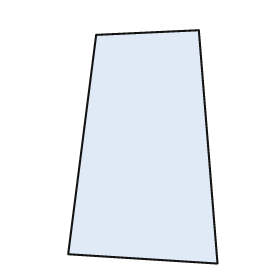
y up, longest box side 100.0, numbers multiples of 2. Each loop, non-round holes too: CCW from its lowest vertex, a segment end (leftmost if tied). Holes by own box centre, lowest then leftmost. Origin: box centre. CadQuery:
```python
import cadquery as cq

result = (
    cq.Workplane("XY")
    .moveTo(32.0, -50.0)
    .lineTo(24.0, 50.0)
    .lineTo(-20.0, 48.0)
    .lineTo(-32.0, -46.0)
    .close()
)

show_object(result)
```